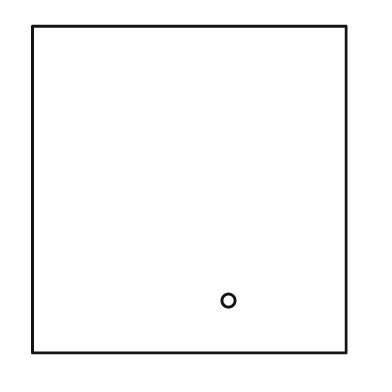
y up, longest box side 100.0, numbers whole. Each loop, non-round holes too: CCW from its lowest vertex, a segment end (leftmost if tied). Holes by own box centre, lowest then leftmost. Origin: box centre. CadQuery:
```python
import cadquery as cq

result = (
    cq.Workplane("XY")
    .moveTo(-48.0, -50.0)
    .lineTo(48.0, -50.0)
    .lineTo(48.0, 50.0)
    .lineTo(-48.0, 50.0)
    .close()
    .moveTo(12.0, -34.0)
    .circle(2.0)
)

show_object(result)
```